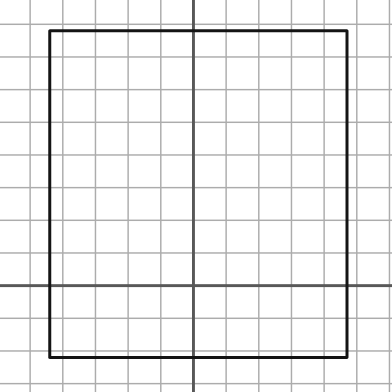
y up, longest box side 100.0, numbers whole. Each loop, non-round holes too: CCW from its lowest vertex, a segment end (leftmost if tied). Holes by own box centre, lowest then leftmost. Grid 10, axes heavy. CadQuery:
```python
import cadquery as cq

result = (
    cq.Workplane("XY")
    .moveTo(-44.0, -22.0)
    .lineTo(47.0, -22.0)
    .lineTo(47.0, 78.0)
    .lineTo(-44.0, 78.0)
    .close()
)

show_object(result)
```